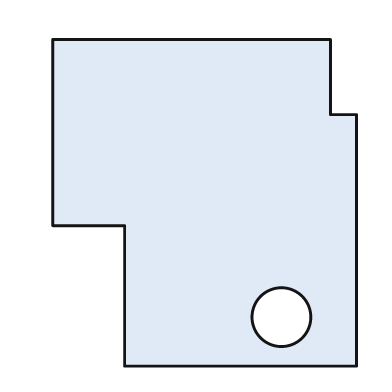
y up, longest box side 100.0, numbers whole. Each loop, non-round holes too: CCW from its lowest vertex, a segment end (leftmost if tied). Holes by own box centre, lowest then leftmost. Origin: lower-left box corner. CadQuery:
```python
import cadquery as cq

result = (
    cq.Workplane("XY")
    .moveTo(22.0, 0.0)
    .lineTo(93.0, 0.0)
    .lineTo(93.0, 77.0)
    .lineTo(85.0, 77.0)
    .lineTo(85.0, 100.0)
    .lineTo(0.0, 100.0)
    .lineTo(0.0, 43.0)
    .lineTo(22.0, 43.0)
    .close()
    .moveTo(70.0, 15.0)
    .circle(9.0)
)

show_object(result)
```